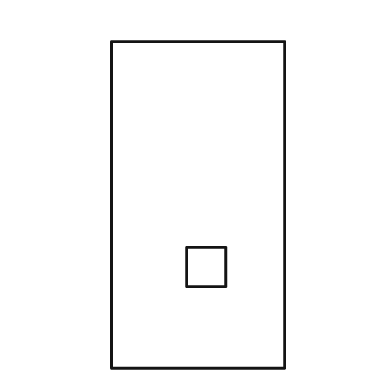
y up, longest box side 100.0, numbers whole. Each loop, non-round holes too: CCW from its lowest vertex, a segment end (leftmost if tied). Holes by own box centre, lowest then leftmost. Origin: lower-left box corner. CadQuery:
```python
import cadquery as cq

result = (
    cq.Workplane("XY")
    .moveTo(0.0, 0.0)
    .lineTo(53.0, 0.0)
    .lineTo(53.0, 100.0)
    .lineTo(0.0, 100.0)
    .close()
    .moveTo(23.0, 25.0)
    .lineTo(35.0, 25.0)
    .lineTo(35.0, 37.0)
    .lineTo(23.0, 37.0)
    .close()
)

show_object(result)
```